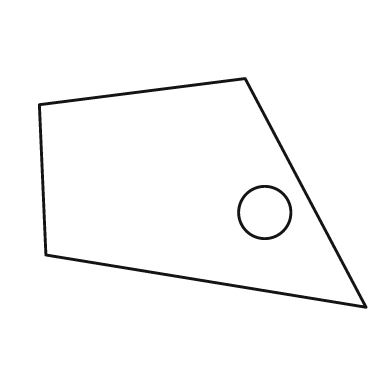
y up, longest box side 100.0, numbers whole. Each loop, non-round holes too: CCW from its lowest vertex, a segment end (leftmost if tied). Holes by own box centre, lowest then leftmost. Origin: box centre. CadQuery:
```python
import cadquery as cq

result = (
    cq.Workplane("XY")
    .moveTo(50.0, -35.0)
    .lineTo(13.0, 35.0)
    .lineTo(-50.0, 27.0)
    .lineTo(-48.0, -19.0)
    .close()
    .moveTo(19.0, -6.0)
    .circle(8.0)
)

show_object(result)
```